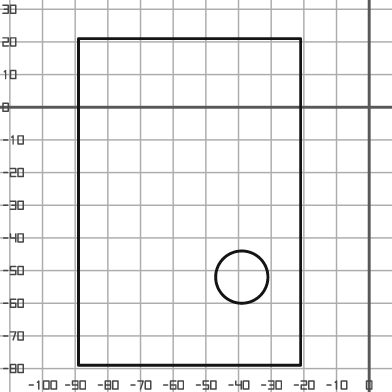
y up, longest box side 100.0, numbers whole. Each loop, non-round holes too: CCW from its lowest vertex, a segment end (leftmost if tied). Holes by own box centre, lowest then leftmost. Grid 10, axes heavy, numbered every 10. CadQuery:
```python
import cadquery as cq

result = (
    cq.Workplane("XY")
    .moveTo(-89.0, -79.0)
    .lineTo(-21.0, -79.0)
    .lineTo(-21.0, 21.0)
    .lineTo(-89.0, 21.0)
    .close()
    .moveTo(-39.0, -52.0)
    .circle(8.0)
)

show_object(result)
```